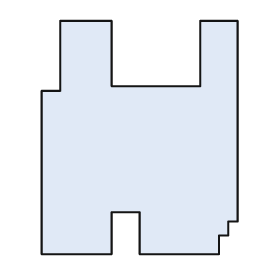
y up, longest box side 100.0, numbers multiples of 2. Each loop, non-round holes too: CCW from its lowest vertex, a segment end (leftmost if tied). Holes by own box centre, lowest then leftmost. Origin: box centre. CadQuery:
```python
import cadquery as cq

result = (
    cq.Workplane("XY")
    .moveTo(-42.0, -50.0)
    .lineTo(-12.0, -50.0)
    .lineTo(-12.0, -32.0)
    .lineTo(0.0, -32.0)
    .lineTo(0.0, -50.0)
    .lineTo(34.0, -50.0)
    .lineTo(34.0, -42.0)
    .lineTo(38.0, -42.0)
    .lineTo(38.0, -36.0)
    .lineTo(42.0, -36.0)
    .lineTo(42.0, 50.0)
    .lineTo(26.0, 50.0)
    .lineTo(26.0, 22.0)
    .lineTo(-12.0, 22.0)
    .lineTo(-12.0, 50.0)
    .lineTo(-34.0, 50.0)
    .lineTo(-34.0, 20.0)
    .lineTo(-42.0, 20.0)
    .close()
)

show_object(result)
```